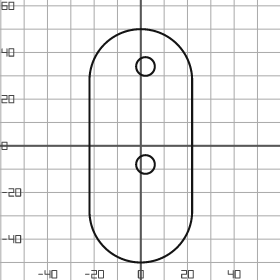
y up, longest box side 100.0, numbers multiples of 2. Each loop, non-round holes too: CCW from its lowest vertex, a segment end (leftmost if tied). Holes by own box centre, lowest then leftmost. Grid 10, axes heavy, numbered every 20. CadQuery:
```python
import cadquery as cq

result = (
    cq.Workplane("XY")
    .moveTo(-22.0, -28.0)
    .threePointArc((0.0, -50.0), (22.0, -28.0))
    .lineTo(22.0, 28.0)
    .threePointArc((0.0, 50.0), (-22.0, 28.0))
    .close()
    .moveTo(2.0, -8.0)
    .circle(4.0)
    .moveTo(2.0, 34.0)
    .circle(4.0)
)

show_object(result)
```